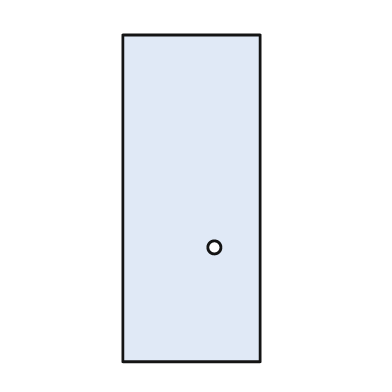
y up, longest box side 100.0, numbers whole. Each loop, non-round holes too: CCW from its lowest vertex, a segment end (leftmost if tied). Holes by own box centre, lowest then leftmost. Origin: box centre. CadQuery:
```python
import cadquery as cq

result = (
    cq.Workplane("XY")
    .moveTo(-21.0, -50.0)
    .lineTo(21.0, -50.0)
    .lineTo(21.0, 50.0)
    .lineTo(-21.0, 50.0)
    .close()
    .moveTo(7.0, -15.0)
    .circle(2.0)
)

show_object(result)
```